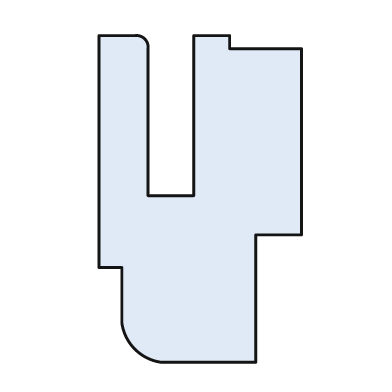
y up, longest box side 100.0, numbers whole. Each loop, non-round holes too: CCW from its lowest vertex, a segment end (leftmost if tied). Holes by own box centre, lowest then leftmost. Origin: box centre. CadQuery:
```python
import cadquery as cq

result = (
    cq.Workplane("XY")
    .moveTo(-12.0, -50.0)
    .lineTo(17.0, -50.0)
    .lineTo(17.0, -11.0)
    .lineTo(31.0, -11.0)
    .lineTo(31.0, 46.0)
    .lineTo(9.0, 46.0)
    .lineTo(9.0, 50.0)
    .lineTo(-2.0, 50.0)
    .lineTo(-2.0, 1.0)
    .lineTo(-16.0, 1.0)
    .lineTo(-16.0, 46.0)
    .threePointArc((-17.0, 49.0), (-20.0, 50.0))
    .lineTo(-31.0, 50.0)
    .lineTo(-31.0, -21.0)
    .lineTo(-24.0, -21.0)
    .lineTo(-24.0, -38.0)
    .threePointArc((-20.0, -46.0), (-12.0, -50.0))
    .close()
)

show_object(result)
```